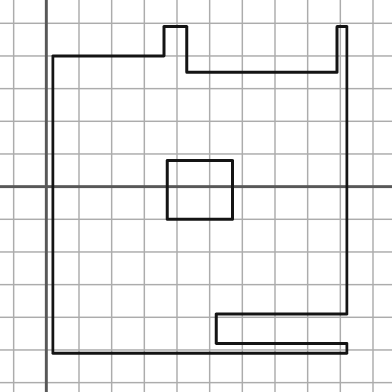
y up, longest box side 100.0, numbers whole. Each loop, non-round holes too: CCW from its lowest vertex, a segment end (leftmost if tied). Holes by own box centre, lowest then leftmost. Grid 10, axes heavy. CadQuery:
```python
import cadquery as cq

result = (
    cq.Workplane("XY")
    .moveTo(2.0, -51.0)
    .lineTo(92.0, -51.0)
    .lineTo(92.0, -48.0)
    .lineTo(52.0, -48.0)
    .lineTo(52.0, -39.0)
    .lineTo(92.0, -39.0)
    .lineTo(92.0, 49.0)
    .lineTo(89.0, 49.0)
    .lineTo(89.0, 35.0)
    .lineTo(43.0, 35.0)
    .lineTo(43.0, 49.0)
    .lineTo(36.0, 49.0)
    .lineTo(36.0, 40.0)
    .lineTo(2.0, 40.0)
    .close()
    .moveTo(37.0, -10.0)
    .lineTo(57.0, -10.0)
    .lineTo(57.0, 8.0)
    .lineTo(37.0, 8.0)
    .close()
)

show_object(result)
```